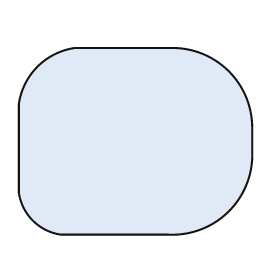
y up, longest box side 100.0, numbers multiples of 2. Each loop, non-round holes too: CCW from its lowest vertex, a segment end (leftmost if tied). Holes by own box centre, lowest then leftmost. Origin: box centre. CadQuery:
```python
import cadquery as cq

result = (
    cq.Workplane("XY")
    .moveTo(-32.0, -40.0)
    .lineTo(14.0, -40.0)
    .threePointArc((40.0, -30.0), (50.0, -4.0))
    .lineTo(50.0, 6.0)
    .threePointArc((40.0, 30.0), (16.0, 40.0))
    .lineTo(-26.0, 40.0)
    .threePointArc((-42.0, 32.0), (-50.0, 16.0))
    .lineTo(-50.0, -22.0)
    .threePointArc((-44.0, -34.0), (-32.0, -40.0))
    .close()
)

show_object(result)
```